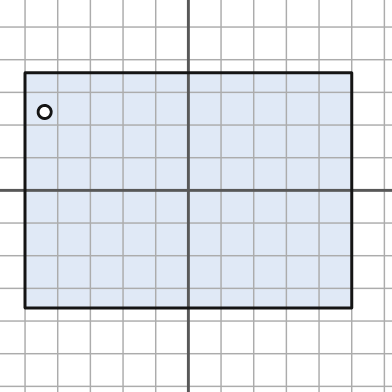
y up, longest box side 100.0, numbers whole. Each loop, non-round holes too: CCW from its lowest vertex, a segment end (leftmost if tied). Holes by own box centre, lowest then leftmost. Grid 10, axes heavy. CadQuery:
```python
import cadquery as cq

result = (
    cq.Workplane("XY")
    .moveTo(-50.0, -36.0)
    .lineTo(50.0, -36.0)
    .lineTo(50.0, 36.0)
    .lineTo(-50.0, 36.0)
    .close()
    .moveTo(-44.0, 24.0)
    .circle(2.0)
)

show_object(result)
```